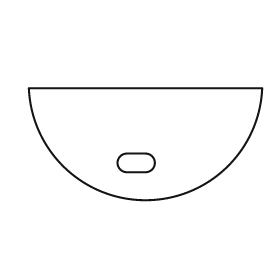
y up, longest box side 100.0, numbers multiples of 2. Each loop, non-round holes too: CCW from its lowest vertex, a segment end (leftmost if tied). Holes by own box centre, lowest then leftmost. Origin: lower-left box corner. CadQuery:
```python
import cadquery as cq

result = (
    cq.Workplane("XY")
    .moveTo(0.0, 48.0)
    .threePointArc((50.0, 0.0), (100.0, 48.0))
    .close()
    .moveTo(42.0, 12.0)
    .lineTo(50.0, 12.0)
    .threePointArc((54.0, 16.0), (50.0, 20.0))
    .lineTo(42.0, 20.0)
    .threePointArc((38.0, 16.0), (42.0, 12.0))
    .close()
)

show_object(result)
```